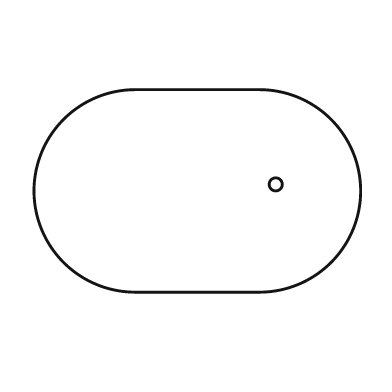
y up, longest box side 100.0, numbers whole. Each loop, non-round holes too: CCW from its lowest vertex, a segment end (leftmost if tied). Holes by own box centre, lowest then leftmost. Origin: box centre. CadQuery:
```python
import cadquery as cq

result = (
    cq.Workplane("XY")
    .moveTo(-19.0, -31.0)
    .lineTo(19.0, -31.0)
    .threePointArc((50.0, 0.0), (19.0, 31.0))
    .lineTo(-19.0, 31.0)
    .threePointArc((-50.0, 0.0), (-19.0, -31.0))
    .close()
    .moveTo(24.0, 2.0)
    .circle(2.0)
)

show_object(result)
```